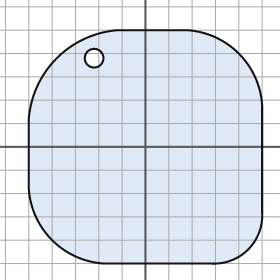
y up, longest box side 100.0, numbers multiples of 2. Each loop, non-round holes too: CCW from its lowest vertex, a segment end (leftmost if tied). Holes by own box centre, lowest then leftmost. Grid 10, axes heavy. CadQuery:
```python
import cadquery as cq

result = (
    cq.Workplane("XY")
    .moveTo(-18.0, -50.0)
    .lineTo(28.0, -50.0)
    .threePointArc((44.0, -44.0), (50.0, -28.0))
    .lineTo(50.0, 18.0)
    .threePointArc((40.0, 40.0), (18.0, 50.0))
    .lineTo(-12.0, 50.0)
    .threePointArc((-38.0, 38.0), (-50.0, 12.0))
    .lineTo(-50.0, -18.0)
    .threePointArc((-40.0, -40.0), (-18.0, -50.0))
    .close()
    .moveTo(-22.0, 38.0)
    .circle(4.0)
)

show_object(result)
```